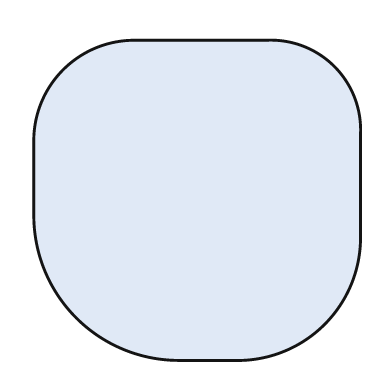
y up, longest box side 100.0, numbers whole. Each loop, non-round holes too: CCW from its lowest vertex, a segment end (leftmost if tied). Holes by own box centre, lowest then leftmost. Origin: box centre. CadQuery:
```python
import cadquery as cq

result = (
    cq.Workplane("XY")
    .moveTo(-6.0, -49.0)
    .lineTo(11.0, -49.0)
    .threePointArc((39.0, -38.0), (50.0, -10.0))
    .lineTo(50.0, 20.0)
    .threePointArc((42.0, 41.0), (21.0, 49.0))
    .lineTo(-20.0, 49.0)
    .threePointArc((-41.0, 40.0), (-50.0, 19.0))
    .lineTo(-50.0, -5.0)
    .threePointArc((-37.0, -36.0), (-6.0, -49.0))
    .close()
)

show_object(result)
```